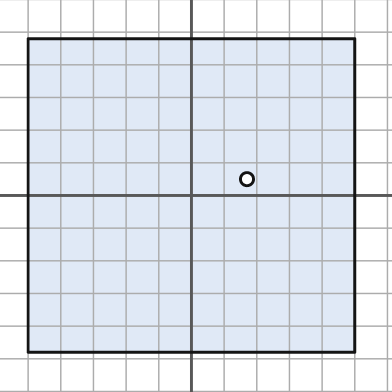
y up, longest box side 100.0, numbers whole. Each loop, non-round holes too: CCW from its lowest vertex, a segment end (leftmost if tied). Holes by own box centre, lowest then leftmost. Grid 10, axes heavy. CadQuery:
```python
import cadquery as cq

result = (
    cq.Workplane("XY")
    .moveTo(-50.0, -48.0)
    .lineTo(50.0, -48.0)
    .lineTo(50.0, 48.0)
    .lineTo(-50.0, 48.0)
    .close()
    .moveTo(17.0, 5.0)
    .circle(2.0)
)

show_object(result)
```